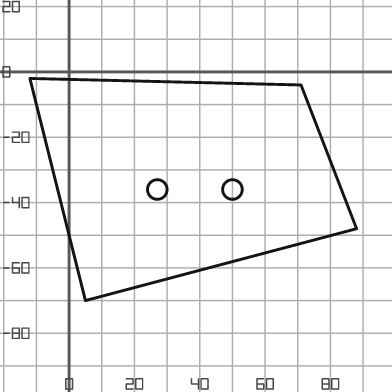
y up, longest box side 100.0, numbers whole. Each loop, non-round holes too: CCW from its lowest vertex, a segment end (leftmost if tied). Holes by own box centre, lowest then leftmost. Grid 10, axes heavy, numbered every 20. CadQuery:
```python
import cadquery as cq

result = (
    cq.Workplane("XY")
    .moveTo(5.0, -70.0)
    .lineTo(88.0, -48.0)
    .lineTo(71.0, -4.0)
    .lineTo(-12.0, -2.0)
    .close()
    .moveTo(27.0, -36.0)
    .circle(3.0)
    .moveTo(50.0, -36.0)
    .circle(3.0)
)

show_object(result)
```